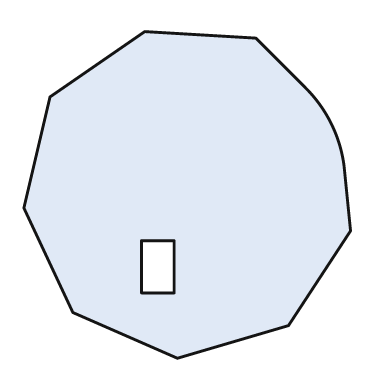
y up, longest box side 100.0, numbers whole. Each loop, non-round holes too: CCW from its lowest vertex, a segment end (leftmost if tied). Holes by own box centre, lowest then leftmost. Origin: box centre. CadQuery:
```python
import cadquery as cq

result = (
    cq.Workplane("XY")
    .moveTo(-3.0, -50.0)
    .lineTo(31.0, -40.0)
    .lineTo(50.0, -11.0)
    .lineTo(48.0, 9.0)
    .threePointArc((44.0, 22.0), (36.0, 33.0))
    .lineTo(21.0, 48.0)
    .lineTo(-13.0, 50.0)
    .lineTo(-42.0, 30.0)
    .lineTo(-50.0, -4.0)
    .lineTo(-35.0, -36.0)
    .close()
    .moveTo(-14.0, -30.0)
    .lineTo(-4.0, -30.0)
    .lineTo(-4.0, -14.0)
    .lineTo(-14.0, -14.0)
    .close()
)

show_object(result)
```